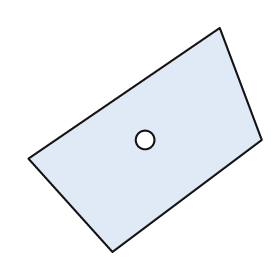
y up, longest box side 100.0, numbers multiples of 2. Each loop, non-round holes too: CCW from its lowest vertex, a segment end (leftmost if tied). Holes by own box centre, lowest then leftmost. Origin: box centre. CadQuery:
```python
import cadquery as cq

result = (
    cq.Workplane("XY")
    .moveTo(-14.0, -48.0)
    .lineTo(50.0, 0.0)
    .lineTo(32.0, 48.0)
    .lineTo(-50.0, -8.0)
    .close()
    .moveTo(0.0, 0.0)
    .circle(4.0)
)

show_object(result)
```